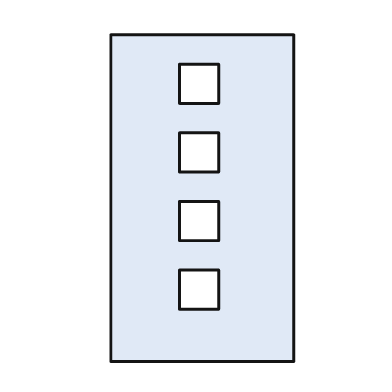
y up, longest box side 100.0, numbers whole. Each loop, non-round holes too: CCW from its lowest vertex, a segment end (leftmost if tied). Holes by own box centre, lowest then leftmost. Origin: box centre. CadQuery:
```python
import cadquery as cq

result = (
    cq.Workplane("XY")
    .moveTo(-28.0, -50.0)
    .lineTo(28.0, -50.0)
    .lineTo(28.0, 50.0)
    .lineTo(-28.0, 50.0)
    .close()
    .moveTo(-7.0, -34.0)
    .lineTo(5.0, -34.0)
    .lineTo(5.0, -22.0)
    .lineTo(-7.0, -22.0)
    .close()
    .moveTo(-7.0, -13.0)
    .lineTo(5.0, -13.0)
    .lineTo(5.0, -1.0)
    .lineTo(-7.0, -1.0)
    .close()
    .moveTo(-7.0, 8.0)
    .lineTo(5.0, 8.0)
    .lineTo(5.0, 20.0)
    .lineTo(-7.0, 20.0)
    .close()
    .moveTo(-7.0, 29.0)
    .lineTo(5.0, 29.0)
    .lineTo(5.0, 41.0)
    .lineTo(-7.0, 41.0)
    .close()
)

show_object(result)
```